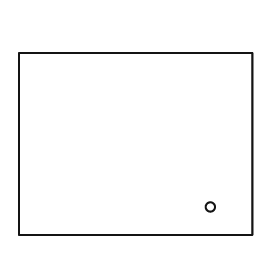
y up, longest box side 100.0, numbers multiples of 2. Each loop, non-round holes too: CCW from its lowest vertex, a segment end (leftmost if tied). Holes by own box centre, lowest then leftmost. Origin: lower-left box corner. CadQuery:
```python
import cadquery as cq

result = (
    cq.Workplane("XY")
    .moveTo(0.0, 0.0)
    .lineTo(100.0, 0.0)
    .lineTo(100.0, 78.0)
    .lineTo(0.0, 78.0)
    .close()
    .moveTo(82.0, 12.0)
    .circle(2.0)
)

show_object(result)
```